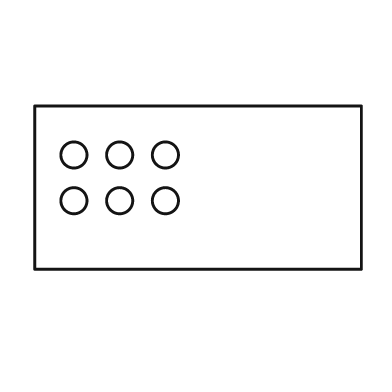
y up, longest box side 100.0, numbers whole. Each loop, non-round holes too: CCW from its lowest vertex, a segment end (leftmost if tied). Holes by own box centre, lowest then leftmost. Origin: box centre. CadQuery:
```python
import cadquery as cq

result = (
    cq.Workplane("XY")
    .moveTo(-50.0, -25.0)
    .lineTo(50.0, -25.0)
    .lineTo(50.0, 25.0)
    .lineTo(-50.0, 25.0)
    .close()
    .moveTo(-38.0, -4.0)
    .circle(4.0)
    .moveTo(-24.0, -4.0)
    .circle(4.0)
    .moveTo(-10.0, -4.0)
    .circle(4.0)
    .moveTo(-38.0, 10.0)
    .circle(4.0)
    .moveTo(-24.0, 10.0)
    .circle(4.0)
    .moveTo(-10.0, 10.0)
    .circle(4.0)
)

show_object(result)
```